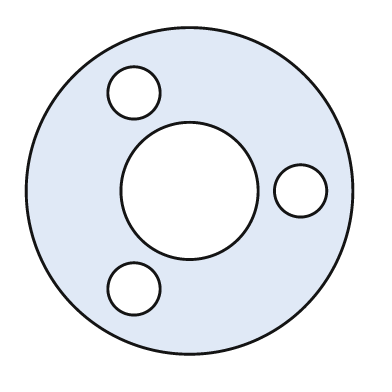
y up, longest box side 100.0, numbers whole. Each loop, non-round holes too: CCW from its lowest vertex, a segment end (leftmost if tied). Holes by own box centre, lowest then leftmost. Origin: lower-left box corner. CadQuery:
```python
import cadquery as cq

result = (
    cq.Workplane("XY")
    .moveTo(50.0, 50.0)
    .circle(50.0)
    .moveTo(33.0, 20.0)
    .circle(8.0)
    .moveTo(50.0, 50.0)
    .circle(21.0)
    .moveTo(84.0, 50.0)
    .circle(8.0)
    .moveTo(33.0, 80.0)
    .circle(8.0)
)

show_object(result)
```